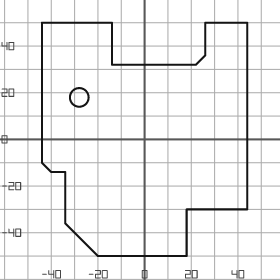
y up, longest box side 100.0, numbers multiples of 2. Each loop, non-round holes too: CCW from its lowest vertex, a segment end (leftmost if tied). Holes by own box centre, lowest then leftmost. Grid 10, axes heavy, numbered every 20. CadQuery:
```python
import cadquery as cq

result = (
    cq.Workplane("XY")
    .moveTo(-20.0, -50.0)
    .lineTo(18.0, -50.0)
    .lineTo(18.0, -30.0)
    .lineTo(44.0, -30.0)
    .lineTo(44.0, 50.0)
    .lineTo(26.0, 50.0)
    .lineTo(26.0, 36.0)
    .lineTo(22.0, 32.0)
    .lineTo(-14.0, 32.0)
    .lineTo(-14.0, 50.0)
    .lineTo(-44.0, 50.0)
    .lineTo(-44.0, -10.0)
    .lineTo(-40.0, -14.0)
    .lineTo(-34.0, -14.0)
    .lineTo(-34.0, -36.0)
    .close()
    .moveTo(-28.0, 18.0)
    .circle(4.0)
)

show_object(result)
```